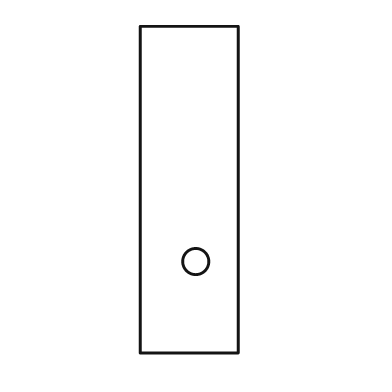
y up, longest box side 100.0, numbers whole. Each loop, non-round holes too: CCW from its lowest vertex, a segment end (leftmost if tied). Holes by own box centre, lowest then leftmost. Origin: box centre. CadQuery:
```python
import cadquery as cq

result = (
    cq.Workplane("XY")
    .moveTo(-15.0, -50.0)
    .lineTo(15.0, -50.0)
    .lineTo(15.0, 50.0)
    .lineTo(-15.0, 50.0)
    .close()
    .moveTo(2.0, -22.0)
    .circle(4.0)
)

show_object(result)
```